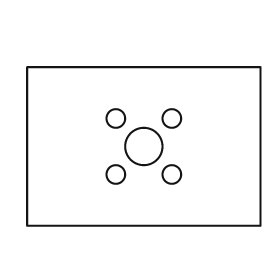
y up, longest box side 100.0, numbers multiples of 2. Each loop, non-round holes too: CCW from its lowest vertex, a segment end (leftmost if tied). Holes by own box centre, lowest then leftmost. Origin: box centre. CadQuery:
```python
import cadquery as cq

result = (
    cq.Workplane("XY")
    .moveTo(-50.0, -34.0)
    .lineTo(50.0, -34.0)
    .lineTo(50.0, 34.0)
    .lineTo(-50.0, 34.0)
    .close()
    .moveTo(-12.0, -12.0)
    .circle(4.0)
    .moveTo(12.0, -12.0)
    .circle(4.0)
    .moveTo(0.0, 0.0)
    .circle(8.0)
    .moveTo(-12.0, 12.0)
    .circle(4.0)
    .moveTo(12.0, 12.0)
    .circle(4.0)
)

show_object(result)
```